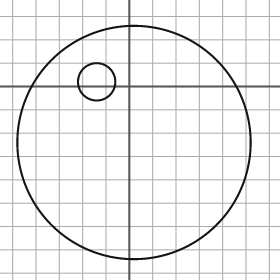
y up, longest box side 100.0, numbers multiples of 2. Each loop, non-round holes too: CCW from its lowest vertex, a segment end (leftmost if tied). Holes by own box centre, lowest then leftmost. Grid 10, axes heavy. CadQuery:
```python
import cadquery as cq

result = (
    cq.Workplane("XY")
    .moveTo(2.0, -24.0)
    .circle(50.0)
    .moveTo(-14.0, 2.0)
    .circle(8.0)
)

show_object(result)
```